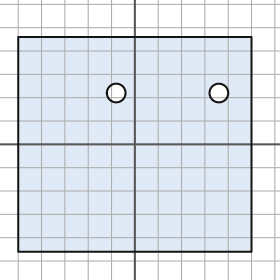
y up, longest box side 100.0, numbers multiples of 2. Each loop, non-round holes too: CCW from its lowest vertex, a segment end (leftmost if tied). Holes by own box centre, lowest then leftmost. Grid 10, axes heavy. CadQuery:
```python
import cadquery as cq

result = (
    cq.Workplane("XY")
    .moveTo(-50.0, -46.0)
    .lineTo(50.0, -46.0)
    .lineTo(50.0, 46.0)
    .lineTo(-50.0, 46.0)
    .close()
    .moveTo(-8.0, 22.0)
    .circle(4.0)
    .moveTo(36.0, 22.0)
    .circle(4.0)
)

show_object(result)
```